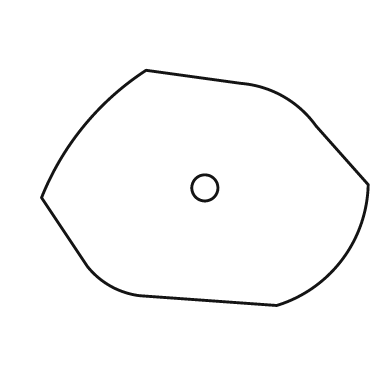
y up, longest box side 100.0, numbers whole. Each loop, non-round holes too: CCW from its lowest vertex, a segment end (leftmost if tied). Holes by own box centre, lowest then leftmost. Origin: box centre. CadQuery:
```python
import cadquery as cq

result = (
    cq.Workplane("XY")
    .moveTo(22.0, -36.0)
    .threePointArc((42.0, -22.0), (50.0, 1.0))
    .lineTo(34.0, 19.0)
    .threePointArc((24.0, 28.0), (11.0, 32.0))
    .lineTo(-18.0, 36.0)
    .threePointArc((-37.0, 19.0), (-50.0, -3.0))
    .lineTo(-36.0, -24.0)
    .threePointArc((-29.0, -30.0), (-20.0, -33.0))
    .close()
    .moveTo(0.0, 0.0)
    .circle(4.0)
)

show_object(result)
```